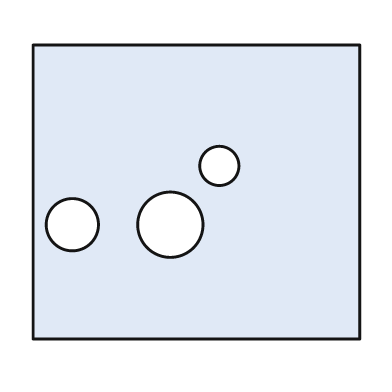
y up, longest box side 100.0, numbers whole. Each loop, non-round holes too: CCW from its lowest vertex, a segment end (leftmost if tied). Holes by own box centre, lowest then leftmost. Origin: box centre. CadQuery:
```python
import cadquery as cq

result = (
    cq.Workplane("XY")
    .moveTo(-50.0, -45.0)
    .lineTo(50.0, -45.0)
    .lineTo(50.0, 45.0)
    .lineTo(-50.0, 45.0)
    .close()
    .moveTo(-38.0, -10.0)
    .circle(8.0)
    .moveTo(-8.0, -10.0)
    .circle(10.0)
    .moveTo(7.0, 8.0)
    .circle(6.0)
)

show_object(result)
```